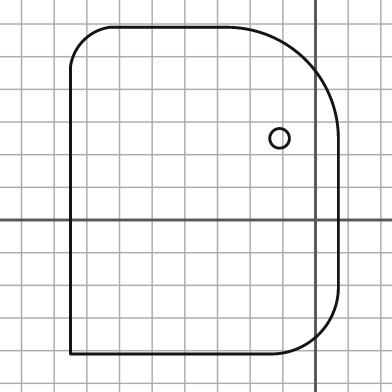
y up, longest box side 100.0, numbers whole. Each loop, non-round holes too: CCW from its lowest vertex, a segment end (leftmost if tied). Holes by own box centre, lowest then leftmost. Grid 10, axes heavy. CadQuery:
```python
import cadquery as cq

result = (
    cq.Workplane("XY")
    .moveTo(-75.0, -41.0)
    .lineTo(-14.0, -41.0)
    .threePointArc((1.0, -35.0), (7.0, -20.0))
    .lineTo(7.0, 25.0)
    .threePointArc((-3.0, 49.0), (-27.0, 59.0))
    .lineTo(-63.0, 59.0)
    .threePointArc((-71.0, 55.0), (-75.0, 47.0))
    .close()
    .moveTo(-11.0, 25.0)
    .circle(3.0)
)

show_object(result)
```